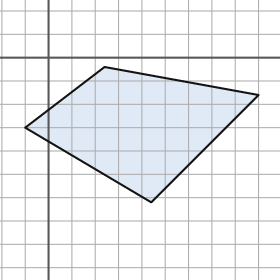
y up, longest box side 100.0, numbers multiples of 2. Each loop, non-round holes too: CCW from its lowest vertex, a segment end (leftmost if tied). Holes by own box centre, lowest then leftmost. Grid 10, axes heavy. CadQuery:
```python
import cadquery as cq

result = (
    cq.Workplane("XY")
    .moveTo(44.0, -62.0)
    .lineTo(90.0, -16.0)
    .lineTo(24.0, -4.0)
    .lineTo(-10.0, -30.0)
    .close()
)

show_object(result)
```